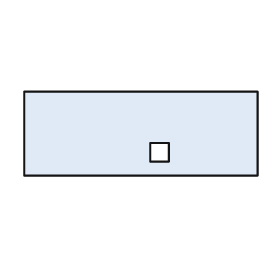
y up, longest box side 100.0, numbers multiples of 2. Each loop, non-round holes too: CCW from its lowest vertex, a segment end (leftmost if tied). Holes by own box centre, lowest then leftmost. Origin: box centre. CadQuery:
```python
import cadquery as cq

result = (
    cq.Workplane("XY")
    .moveTo(-50.0, -18.0)
    .lineTo(50.0, -18.0)
    .lineTo(50.0, 18.0)
    .lineTo(-50.0, 18.0)
    .close()
    .moveTo(4.0, -12.0)
    .lineTo(12.0, -12.0)
    .lineTo(12.0, -4.0)
    .lineTo(4.0, -4.0)
    .close()
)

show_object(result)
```